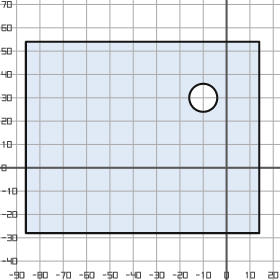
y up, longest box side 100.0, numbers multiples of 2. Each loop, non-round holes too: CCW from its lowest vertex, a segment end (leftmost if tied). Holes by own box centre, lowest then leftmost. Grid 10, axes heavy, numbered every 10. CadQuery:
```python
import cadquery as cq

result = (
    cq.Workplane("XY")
    .moveTo(-86.0, -28.0)
    .lineTo(14.0, -28.0)
    .lineTo(14.0, 54.0)
    .lineTo(-86.0, 54.0)
    .close()
    .moveTo(-10.0, 30.0)
    .circle(6.0)
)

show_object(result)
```